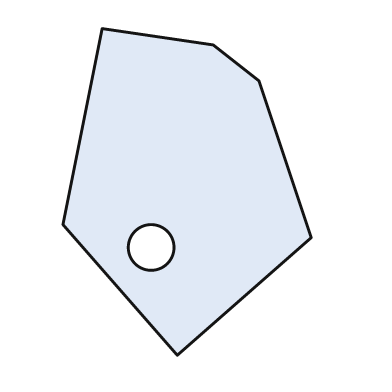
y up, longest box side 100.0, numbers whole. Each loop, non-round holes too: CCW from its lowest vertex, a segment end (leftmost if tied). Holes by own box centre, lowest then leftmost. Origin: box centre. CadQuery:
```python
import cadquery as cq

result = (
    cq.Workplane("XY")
    .moveTo(-3.0, -50.0)
    .lineTo(38.0, -14.0)
    .lineTo(22.0, 34.0)
    .lineTo(8.0, 45.0)
    .lineTo(-26.0, 50.0)
    .lineTo(-38.0, -10.0)
    .close()
    .moveTo(-11.0, -17.0)
    .circle(7.0)
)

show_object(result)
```